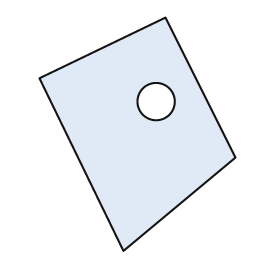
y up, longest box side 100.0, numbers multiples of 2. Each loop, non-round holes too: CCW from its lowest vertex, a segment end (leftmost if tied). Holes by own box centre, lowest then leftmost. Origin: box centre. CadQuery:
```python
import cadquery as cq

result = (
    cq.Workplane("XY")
    .moveTo(-6.0, -50.0)
    .lineTo(42.0, -10.0)
    .lineTo(12.0, 50.0)
    .lineTo(-42.0, 24.0)
    .close()
    .moveTo(8.0, 14.0)
    .circle(8.0)
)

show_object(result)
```